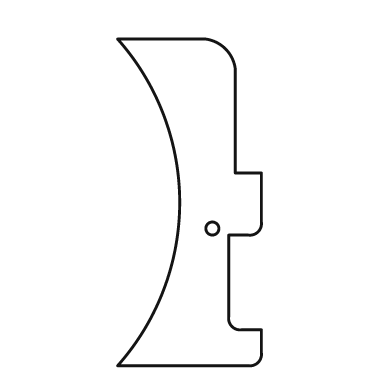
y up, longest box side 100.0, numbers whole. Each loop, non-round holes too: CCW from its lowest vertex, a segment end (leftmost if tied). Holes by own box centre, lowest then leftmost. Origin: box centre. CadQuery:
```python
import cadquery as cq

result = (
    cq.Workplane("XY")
    .moveTo(-22.0, -50.0)
    .lineTo(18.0, -50.0)
    .threePointArc((21.0, -49.0), (22.0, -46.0))
    .lineTo(22.0, -39.0)
    .lineTo(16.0, -39.0)
    .threePointArc((13.0, -38.0), (12.0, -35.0))
    .lineTo(12.0, -10.0)
    .lineTo(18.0, -10.0)
    .threePointArc((21.0, -9.0), (22.0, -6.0))
    .lineTo(22.0, 9.0)
    .lineTo(14.0, 9.0)
    .lineTo(14.0, 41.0)
    .threePointArc((11.0, 47.0), (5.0, 50.0))
    .lineTo(-22.0, 50.0)
    .threePointArc((-3.0, 0.0), (-22.0, -50.0))
    .close()
    .moveTo(7.0, -8.0)
    .circle(2.0)
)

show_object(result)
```